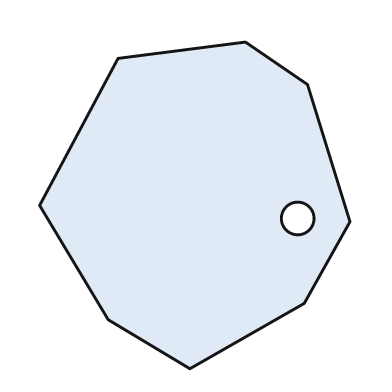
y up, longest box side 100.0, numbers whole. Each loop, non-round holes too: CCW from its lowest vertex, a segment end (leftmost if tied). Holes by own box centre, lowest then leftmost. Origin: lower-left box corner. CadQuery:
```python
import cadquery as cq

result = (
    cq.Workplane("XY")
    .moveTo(46.0, 0.0)
    .lineTo(81.0, 20.0)
    .lineTo(95.0, 45.0)
    .lineTo(82.0, 87.0)
    .lineTo(63.0, 100.0)
    .lineTo(24.0, 95.0)
    .lineTo(0.0, 50.0)
    .lineTo(21.0, 15.0)
    .close()
    .moveTo(79.0, 46.0)
    .circle(5.0)
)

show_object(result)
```